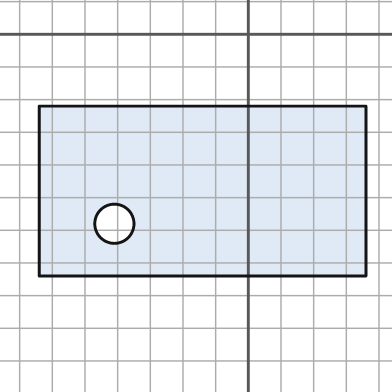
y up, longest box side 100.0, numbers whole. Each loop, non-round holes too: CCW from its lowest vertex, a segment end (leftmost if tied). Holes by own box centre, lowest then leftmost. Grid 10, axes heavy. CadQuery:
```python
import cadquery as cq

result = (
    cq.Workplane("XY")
    .moveTo(-64.0, -74.0)
    .lineTo(36.0, -74.0)
    .lineTo(36.0, -22.0)
    .lineTo(-64.0, -22.0)
    .close()
    .moveTo(-41.0, -58.0)
    .circle(6.0)
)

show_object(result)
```